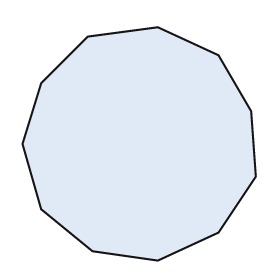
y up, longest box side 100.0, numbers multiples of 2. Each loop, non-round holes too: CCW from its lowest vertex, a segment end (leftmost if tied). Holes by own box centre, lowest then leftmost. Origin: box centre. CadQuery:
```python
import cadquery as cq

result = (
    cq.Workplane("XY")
    .moveTo(8.0, -50.0)
    .lineTo(34.0, -38.0)
    .lineTo(50.0, -14.0)
    .lineTo(48.0, 14.0)
    .lineTo(34.0, 38.0)
    .lineTo(8.0, 50.0)
    .lineTo(-22.0, 46.0)
    .lineTo(-42.0, 26.0)
    .lineTo(-50.0, 0.0)
    .lineTo(-42.0, -28.0)
    .lineTo(-20.0, -46.0)
    .close()
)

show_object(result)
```